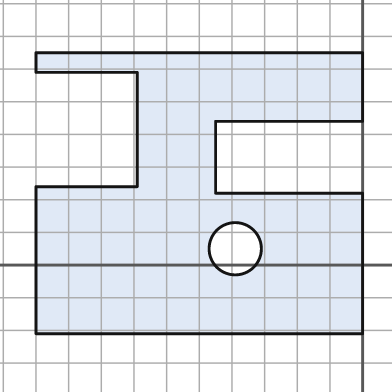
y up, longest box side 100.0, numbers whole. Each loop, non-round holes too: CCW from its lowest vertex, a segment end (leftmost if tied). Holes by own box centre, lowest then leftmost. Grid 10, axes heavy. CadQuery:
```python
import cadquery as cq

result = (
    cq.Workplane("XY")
    .moveTo(-100.0, -21.0)
    .lineTo(0.0, -21.0)
    .lineTo(0.0, 22.0)
    .lineTo(-45.0, 22.0)
    .lineTo(-45.0, 44.0)
    .lineTo(0.0, 44.0)
    .lineTo(0.0, 65.0)
    .lineTo(-100.0, 65.0)
    .lineTo(-100.0, 59.0)
    .lineTo(-69.0, 59.0)
    .lineTo(-69.0, 24.0)
    .lineTo(-100.0, 24.0)
    .close()
    .moveTo(-39.0, 5.0)
    .circle(8.0)
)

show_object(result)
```